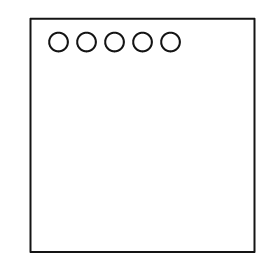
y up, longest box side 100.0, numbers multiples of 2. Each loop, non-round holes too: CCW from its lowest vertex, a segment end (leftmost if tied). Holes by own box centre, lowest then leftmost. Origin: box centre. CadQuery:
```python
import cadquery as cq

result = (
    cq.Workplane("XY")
    .moveTo(-48.0, -50.0)
    .lineTo(48.0, -50.0)
    .lineTo(48.0, 50.0)
    .lineTo(-48.0, 50.0)
    .close()
    .moveTo(-36.0, 40.0)
    .circle(4.0)
    .moveTo(-24.0, 40.0)
    .circle(4.0)
    .moveTo(-12.0, 40.0)
    .circle(4.0)
    .moveTo(0.0, 40.0)
    .circle(4.0)
    .moveTo(12.0, 40.0)
    .circle(4.0)
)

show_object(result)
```